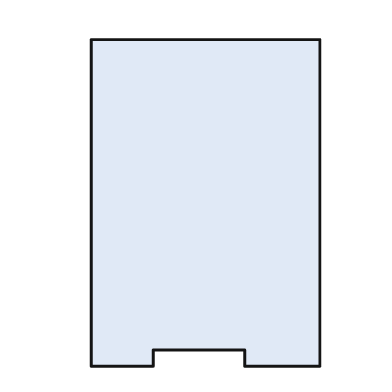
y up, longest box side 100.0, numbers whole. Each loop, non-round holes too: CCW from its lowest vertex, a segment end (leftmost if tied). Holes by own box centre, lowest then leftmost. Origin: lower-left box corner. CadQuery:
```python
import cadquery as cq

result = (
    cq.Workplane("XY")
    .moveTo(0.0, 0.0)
    .lineTo(19.0, 0.0)
    .lineTo(19.0, 5.0)
    .lineTo(47.0, 5.0)
    .lineTo(47.0, 0.0)
    .lineTo(70.0, 0.0)
    .lineTo(70.0, 100.0)
    .lineTo(0.0, 100.0)
    .close()
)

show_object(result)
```